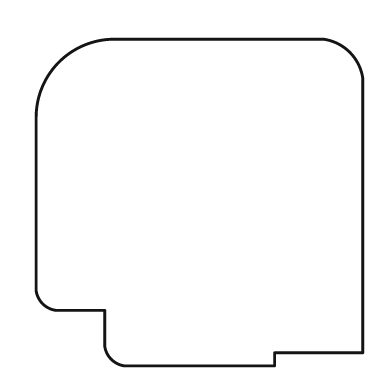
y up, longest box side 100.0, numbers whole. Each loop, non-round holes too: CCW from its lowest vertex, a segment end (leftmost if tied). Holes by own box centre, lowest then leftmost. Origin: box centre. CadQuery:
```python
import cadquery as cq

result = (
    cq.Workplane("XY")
    .moveTo(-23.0, -50.0)
    .lineTo(23.0, -50.0)
    .lineTo(23.0, -46.0)
    .lineTo(50.0, -46.0)
    .lineTo(50.0, 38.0)
    .threePointArc((46.0, 46.0), (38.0, 50.0))
    .lineTo(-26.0, 50.0)
    .threePointArc((-43.0, 43.0), (-50.0, 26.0))
    .lineTo(-50.0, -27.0)
    .threePointArc((-48.0, -31.0), (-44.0, -33.0))
    .lineTo(-29.0, -33.0)
    .lineTo(-29.0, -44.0)
    .threePointArc((-27.0, -48.0), (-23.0, -50.0))
    .close()
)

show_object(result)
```